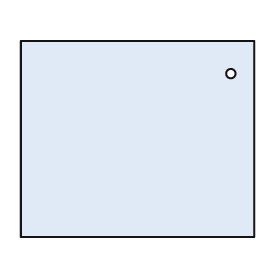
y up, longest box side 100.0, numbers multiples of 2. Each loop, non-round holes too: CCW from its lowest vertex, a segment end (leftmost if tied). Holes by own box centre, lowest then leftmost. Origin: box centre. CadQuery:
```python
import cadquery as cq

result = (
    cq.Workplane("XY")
    .moveTo(-50.0, -42.0)
    .lineTo(50.0, -42.0)
    .lineTo(50.0, 42.0)
    .lineTo(-50.0, 42.0)
    .close()
    .moveTo(40.0, 28.0)
    .circle(2.0)
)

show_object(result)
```